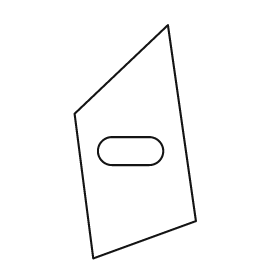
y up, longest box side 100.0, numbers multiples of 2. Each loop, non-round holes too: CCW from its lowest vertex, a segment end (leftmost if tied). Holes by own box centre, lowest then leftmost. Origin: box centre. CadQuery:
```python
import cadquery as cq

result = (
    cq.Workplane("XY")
    .moveTo(-18.0, -50.0)
    .lineTo(26.0, -34.0)
    .lineTo(14.0, 50.0)
    .lineTo(-26.0, 12.0)
    .close()
    .moveTo(-10.0, -10.0)
    .lineTo(6.0, -10.0)
    .threePointArc((12.0, -4.0), (6.0, 2.0))
    .lineTo(-10.0, 2.0)
    .threePointArc((-16.0, -4.0), (-10.0, -10.0))
    .close()
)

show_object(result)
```